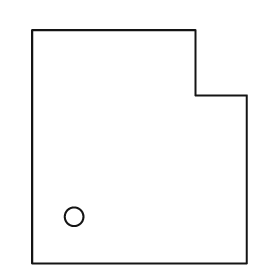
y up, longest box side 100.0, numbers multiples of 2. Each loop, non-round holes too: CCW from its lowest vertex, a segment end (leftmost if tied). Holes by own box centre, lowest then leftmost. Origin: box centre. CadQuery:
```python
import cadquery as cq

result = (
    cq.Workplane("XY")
    .moveTo(-46.0, -50.0)
    .lineTo(46.0, -50.0)
    .lineTo(46.0, 22.0)
    .lineTo(24.0, 22.0)
    .lineTo(24.0, 50.0)
    .lineTo(-46.0, 50.0)
    .close()
    .moveTo(-28.0, -30.0)
    .circle(4.0)
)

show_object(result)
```